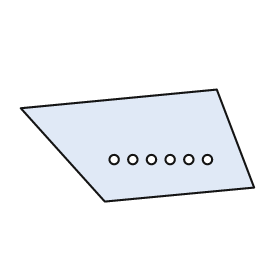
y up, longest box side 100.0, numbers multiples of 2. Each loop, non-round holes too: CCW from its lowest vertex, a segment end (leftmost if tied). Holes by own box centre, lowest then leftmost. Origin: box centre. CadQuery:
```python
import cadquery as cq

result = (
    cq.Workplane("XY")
    .moveTo(-14.0, -24.0)
    .lineTo(50.0, -18.0)
    .lineTo(34.0, 24.0)
    .lineTo(-50.0, 16.0)
    .close()
    .moveTo(-10.0, -6.0)
    .circle(2.0)
    .moveTo(-2.0, -6.0)
    .circle(2.0)
    .moveTo(6.0, -6.0)
    .circle(2.0)
    .moveTo(14.0, -6.0)
    .circle(2.0)
    .moveTo(22.0, -6.0)
    .circle(2.0)
    .moveTo(30.0, -6.0)
    .circle(2.0)
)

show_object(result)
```